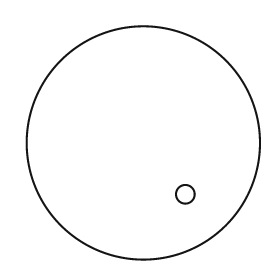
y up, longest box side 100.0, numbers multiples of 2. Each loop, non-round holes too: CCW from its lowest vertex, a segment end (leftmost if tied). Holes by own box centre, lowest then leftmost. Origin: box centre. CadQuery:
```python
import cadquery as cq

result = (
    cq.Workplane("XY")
    .moveTo(0.0, 0.0)
    .circle(50.0)
    .moveTo(18.0, -22.0)
    .circle(4.0)
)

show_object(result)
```